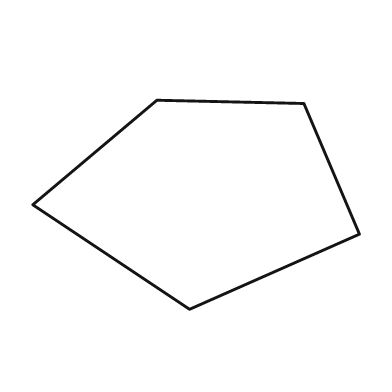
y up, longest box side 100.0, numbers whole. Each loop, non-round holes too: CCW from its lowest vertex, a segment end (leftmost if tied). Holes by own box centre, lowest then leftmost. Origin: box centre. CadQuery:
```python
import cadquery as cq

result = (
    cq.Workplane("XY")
    .moveTo(-2.0, -32.0)
    .lineTo(50.0, -9.0)
    .lineTo(33.0, 31.0)
    .lineTo(-12.0, 32.0)
    .lineTo(-50.0, 0.0)
    .close()
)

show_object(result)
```